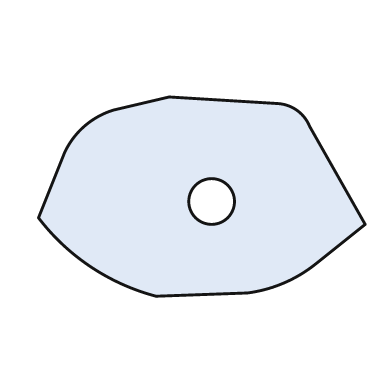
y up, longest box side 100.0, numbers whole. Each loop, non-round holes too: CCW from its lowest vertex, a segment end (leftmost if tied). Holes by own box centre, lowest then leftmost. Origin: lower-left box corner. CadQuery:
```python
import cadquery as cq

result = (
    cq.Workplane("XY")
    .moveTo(36.0, 0.0)
    .lineTo(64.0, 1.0)
    .threePointArc((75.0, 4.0), (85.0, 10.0))
    .lineTo(100.0, 22.0)
    .lineTo(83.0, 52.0)
    .threePointArc((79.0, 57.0), (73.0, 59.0))
    .lineTo(40.0, 61.0)
    .lineTo(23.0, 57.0)
    .threePointArc((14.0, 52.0), (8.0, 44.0))
    .lineTo(0.0, 24.0)
    .threePointArc((16.0, 9.0), (36.0, 0.0))
    .close()
    .moveTo(53.0, 29.0)
    .circle(7.0)
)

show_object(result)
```